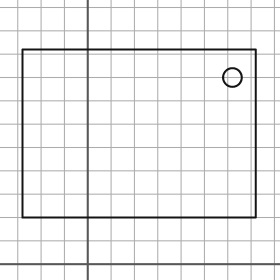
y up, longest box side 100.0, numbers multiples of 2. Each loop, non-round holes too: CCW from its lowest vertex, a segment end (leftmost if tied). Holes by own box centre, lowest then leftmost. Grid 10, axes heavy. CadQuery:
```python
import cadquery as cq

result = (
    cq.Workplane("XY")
    .moveTo(-28.0, 20.0)
    .lineTo(72.0, 20.0)
    .lineTo(72.0, 92.0)
    .lineTo(-28.0, 92.0)
    .close()
    .moveTo(62.0, 80.0)
    .circle(4.0)
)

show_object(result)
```